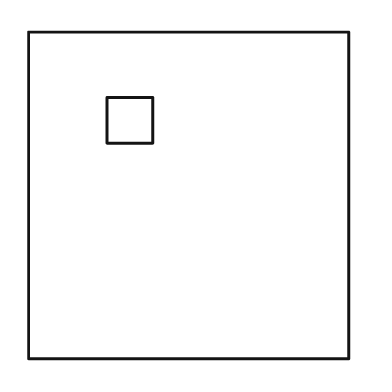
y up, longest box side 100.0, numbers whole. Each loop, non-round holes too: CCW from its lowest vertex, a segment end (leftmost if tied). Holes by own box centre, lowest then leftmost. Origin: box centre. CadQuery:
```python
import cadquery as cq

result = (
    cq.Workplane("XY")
    .moveTo(-49.0, -50.0)
    .lineTo(49.0, -50.0)
    .lineTo(49.0, 50.0)
    .lineTo(-49.0, 50.0)
    .close()
    .moveTo(-25.0, 16.0)
    .lineTo(-11.0, 16.0)
    .lineTo(-11.0, 30.0)
    .lineTo(-25.0, 30.0)
    .close()
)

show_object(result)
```